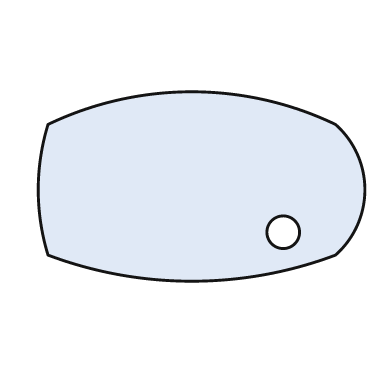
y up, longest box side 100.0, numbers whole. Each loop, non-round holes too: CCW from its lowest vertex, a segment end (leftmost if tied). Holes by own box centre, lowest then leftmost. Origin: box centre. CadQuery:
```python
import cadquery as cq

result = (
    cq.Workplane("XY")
    .moveTo(-47.0, -21.0)
    .threePointArc((-3.0, -29.0), (41.0, -21.0))
    .threePointArc((50.0, -1.0), (41.0, 19.0))
    .threePointArc((-3.0, 29.0), (-47.0, 19.0))
    .threePointArc((-50.0, -1.0), (-47.0, -21.0))
    .close()
    .moveTo(25.0, -14.0)
    .circle(5.0)
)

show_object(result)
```